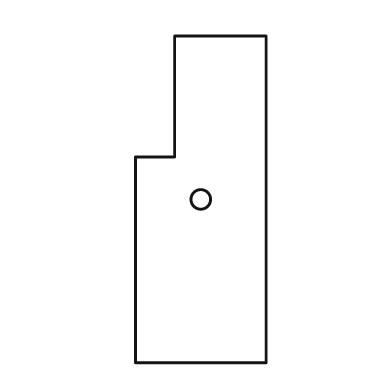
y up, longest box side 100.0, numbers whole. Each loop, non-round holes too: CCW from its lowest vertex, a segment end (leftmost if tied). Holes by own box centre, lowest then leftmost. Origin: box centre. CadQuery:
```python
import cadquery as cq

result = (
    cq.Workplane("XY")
    .moveTo(-20.0, -50.0)
    .lineTo(20.0, -50.0)
    .lineTo(20.0, 50.0)
    .lineTo(-8.0, 50.0)
    .lineTo(-8.0, 13.0)
    .lineTo(-20.0, 13.0)
    .close()
    .moveTo(0.0, 0.0)
    .circle(3.0)
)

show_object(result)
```